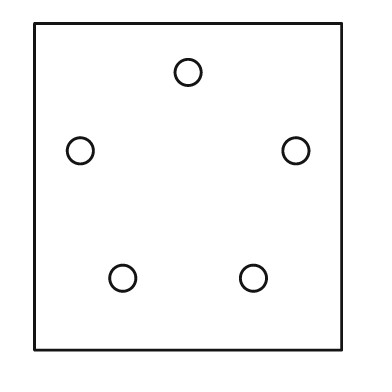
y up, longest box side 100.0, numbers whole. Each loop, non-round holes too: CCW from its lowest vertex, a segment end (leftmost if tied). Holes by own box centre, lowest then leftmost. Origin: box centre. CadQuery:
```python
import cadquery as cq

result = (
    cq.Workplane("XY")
    .moveTo(-47.0, -50.0)
    .lineTo(47.0, -50.0)
    .lineTo(47.0, 50.0)
    .lineTo(-47.0, 50.0)
    .close()
    .moveTo(-20.0, -28.0)
    .circle(4.0)
    .moveTo(20.0, -28.0)
    .circle(4.0)
    .moveTo(-33.0, 11.0)
    .circle(4.0)
    .moveTo(33.0, 11.0)
    .circle(4.0)
    .moveTo(0.0, 35.0)
    .circle(4.0)
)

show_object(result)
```